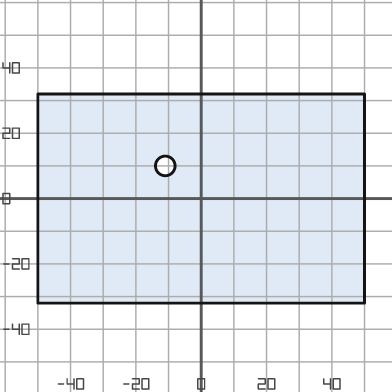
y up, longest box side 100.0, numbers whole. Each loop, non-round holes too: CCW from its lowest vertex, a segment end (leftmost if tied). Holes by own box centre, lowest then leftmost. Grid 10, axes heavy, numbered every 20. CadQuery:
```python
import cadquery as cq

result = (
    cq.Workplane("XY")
    .moveTo(-50.0, -32.0)
    .lineTo(50.0, -32.0)
    .lineTo(50.0, 32.0)
    .lineTo(-50.0, 32.0)
    .close()
    .moveTo(-11.0, 10.0)
    .circle(3.0)
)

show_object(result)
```